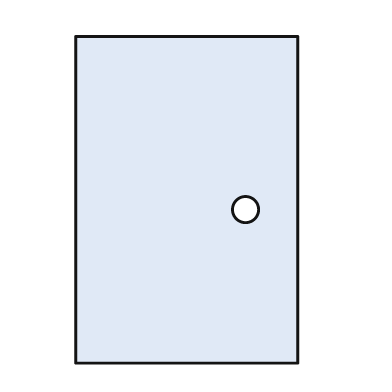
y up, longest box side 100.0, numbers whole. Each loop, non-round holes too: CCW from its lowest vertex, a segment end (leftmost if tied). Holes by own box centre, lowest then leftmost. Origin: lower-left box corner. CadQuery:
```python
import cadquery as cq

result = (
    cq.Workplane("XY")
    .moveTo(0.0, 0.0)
    .lineTo(68.0, 0.0)
    .lineTo(68.0, 100.0)
    .lineTo(0.0, 100.0)
    .close()
    .moveTo(52.0, 47.0)
    .circle(4.0)
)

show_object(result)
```